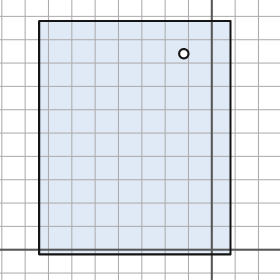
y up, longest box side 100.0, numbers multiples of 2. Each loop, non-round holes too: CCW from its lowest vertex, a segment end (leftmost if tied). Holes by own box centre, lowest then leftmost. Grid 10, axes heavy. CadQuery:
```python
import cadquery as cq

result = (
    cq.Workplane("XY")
    .moveTo(-74.0, -2.0)
    .lineTo(8.0, -2.0)
    .lineTo(8.0, 98.0)
    .lineTo(-74.0, 98.0)
    .close()
    .moveTo(-12.0, 84.0)
    .circle(2.0)
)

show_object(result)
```